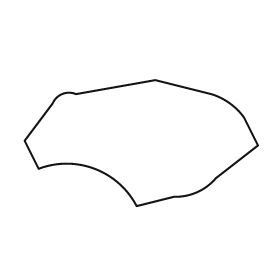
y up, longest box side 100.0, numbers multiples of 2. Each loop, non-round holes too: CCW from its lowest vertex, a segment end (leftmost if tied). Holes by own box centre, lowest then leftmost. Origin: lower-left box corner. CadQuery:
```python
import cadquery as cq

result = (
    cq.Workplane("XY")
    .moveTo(48.0, 0.0)
    .lineTo(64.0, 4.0)
    .threePointArc((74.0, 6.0), (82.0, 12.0))
    .lineTo(100.0, 26.0)
    .lineTo(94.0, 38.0)
    .threePointArc((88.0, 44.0), (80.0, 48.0))
    .lineTo(56.0, 54.0)
    .lineTo(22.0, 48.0)
    .threePointArc((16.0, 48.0), (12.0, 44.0))
    .lineTo(0.0, 28.0)
    .lineTo(6.0, 16.0)
    .threePointArc((30.0, 16.0), (48.0, 0.0))
    .close()
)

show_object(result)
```